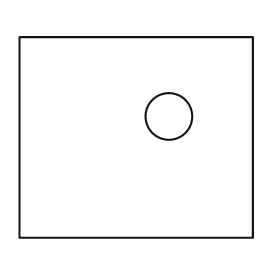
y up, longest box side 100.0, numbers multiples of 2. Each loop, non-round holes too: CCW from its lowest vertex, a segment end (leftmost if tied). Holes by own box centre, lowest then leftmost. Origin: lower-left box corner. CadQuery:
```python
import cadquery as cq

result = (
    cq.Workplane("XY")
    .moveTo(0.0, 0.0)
    .lineTo(100.0, 0.0)
    .lineTo(100.0, 86.0)
    .lineTo(0.0, 86.0)
    .close()
    .moveTo(64.0, 52.0)
    .circle(10.0)
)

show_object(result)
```